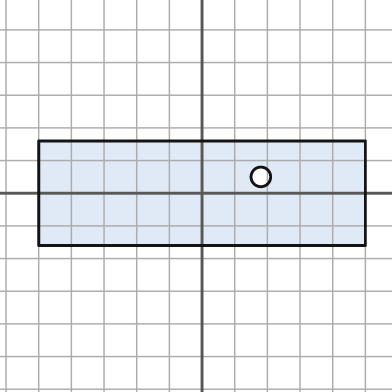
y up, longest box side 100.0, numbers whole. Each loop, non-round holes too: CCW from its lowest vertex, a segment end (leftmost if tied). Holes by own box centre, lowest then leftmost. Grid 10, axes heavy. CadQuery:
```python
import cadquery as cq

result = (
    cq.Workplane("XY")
    .moveTo(-50.0, -16.0)
    .lineTo(50.0, -16.0)
    .lineTo(50.0, 16.0)
    .lineTo(-50.0, 16.0)
    .close()
    .moveTo(18.0, 5.0)
    .circle(3.0)
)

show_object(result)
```